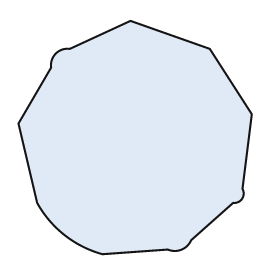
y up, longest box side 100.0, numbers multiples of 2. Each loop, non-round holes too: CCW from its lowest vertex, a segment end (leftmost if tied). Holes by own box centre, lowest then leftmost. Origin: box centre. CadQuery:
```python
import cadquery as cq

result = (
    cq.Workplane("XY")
    .moveTo(-14.0, -50.0)
    .lineTo(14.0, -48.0)
    .threePointArc((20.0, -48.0), (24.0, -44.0))
    .lineTo(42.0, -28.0)
    .threePointArc((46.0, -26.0), (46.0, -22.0))
    .lineTo(50.0, 10.0)
    .lineTo(32.0, 38.0)
    .lineTo(-2.0, 50.0)
    .lineTo(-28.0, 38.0)
    .threePointArc((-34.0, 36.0), (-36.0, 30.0))
    .lineTo(-50.0, 6.0)
    .lineTo(-42.0, -28.0)
    .threePointArc((-30.0, -42.0), (-14.0, -50.0))
    .close()
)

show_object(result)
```